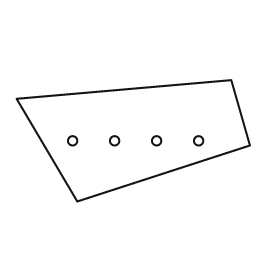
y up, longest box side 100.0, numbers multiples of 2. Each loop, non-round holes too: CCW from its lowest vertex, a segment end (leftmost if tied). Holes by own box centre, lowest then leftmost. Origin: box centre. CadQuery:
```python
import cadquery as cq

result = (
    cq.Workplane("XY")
    .moveTo(-24.0, -26.0)
    .lineTo(50.0, -2.0)
    .lineTo(42.0, 26.0)
    .lineTo(-50.0, 18.0)
    .close()
    .moveTo(-26.0, 0.0)
    .circle(2.0)
    .moveTo(-8.0, 0.0)
    .circle(2.0)
    .moveTo(10.0, 0.0)
    .circle(2.0)
    .moveTo(28.0, 0.0)
    .circle(2.0)
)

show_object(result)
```